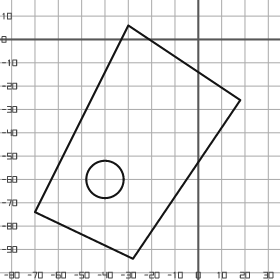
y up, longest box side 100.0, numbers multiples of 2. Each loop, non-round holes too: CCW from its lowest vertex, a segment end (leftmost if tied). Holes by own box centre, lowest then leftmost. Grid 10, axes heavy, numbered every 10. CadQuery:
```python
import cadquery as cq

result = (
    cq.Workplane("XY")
    .moveTo(-28.0, -94.0)
    .lineTo(18.0, -26.0)
    .lineTo(-30.0, 6.0)
    .lineTo(-70.0, -74.0)
    .close()
    .moveTo(-40.0, -60.0)
    .circle(8.0)
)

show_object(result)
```